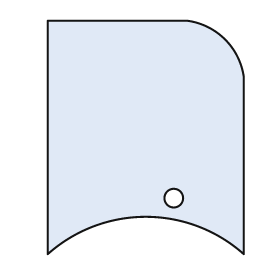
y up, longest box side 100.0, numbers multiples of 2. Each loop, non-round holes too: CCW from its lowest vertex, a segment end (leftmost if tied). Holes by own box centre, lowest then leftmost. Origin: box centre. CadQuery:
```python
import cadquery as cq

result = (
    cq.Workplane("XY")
    .moveTo(-42.0, -50.0)
    .threePointArc((0.0, -34.0), (42.0, -50.0))
    .lineTo(42.0, 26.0)
    .threePointArc((34.0, 42.0), (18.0, 50.0))
    .lineTo(-42.0, 50.0)
    .close()
    .moveTo(12.0, -26.0)
    .circle(4.0)
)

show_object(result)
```